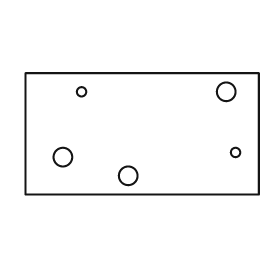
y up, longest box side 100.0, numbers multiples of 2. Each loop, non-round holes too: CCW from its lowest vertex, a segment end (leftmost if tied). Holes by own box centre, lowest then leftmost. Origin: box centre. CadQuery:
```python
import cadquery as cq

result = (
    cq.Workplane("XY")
    .moveTo(-50.0, -26.0)
    .lineTo(50.0, -26.0)
    .lineTo(50.0, 26.0)
    .lineTo(-50.0, 26.0)
    .close()
    .moveTo(-6.0, -18.0)
    .circle(4.0)
    .moveTo(-34.0, -10.0)
    .circle(4.0)
    .moveTo(40.0, -8.0)
    .circle(2.0)
    .moveTo(-26.0, 18.0)
    .circle(2.0)
    .moveTo(36.0, 18.0)
    .circle(4.0)
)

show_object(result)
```